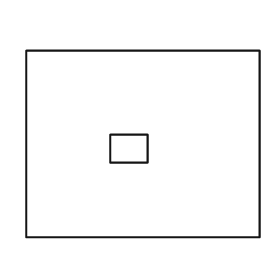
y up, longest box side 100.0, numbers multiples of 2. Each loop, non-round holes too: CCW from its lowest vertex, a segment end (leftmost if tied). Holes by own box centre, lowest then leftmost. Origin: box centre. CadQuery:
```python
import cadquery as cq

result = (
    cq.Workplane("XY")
    .moveTo(-50.0, -40.0)
    .lineTo(50.0, -40.0)
    .lineTo(50.0, 40.0)
    .lineTo(-50.0, 40.0)
    .close()
    .moveTo(-14.0, -8.0)
    .lineTo(2.0, -8.0)
    .lineTo(2.0, 4.0)
    .lineTo(-14.0, 4.0)
    .close()
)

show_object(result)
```